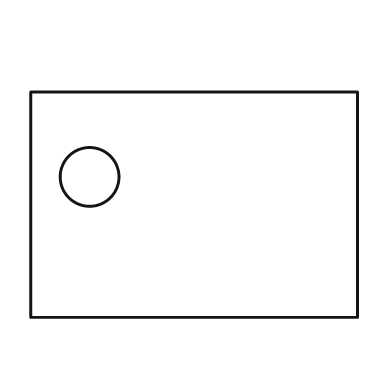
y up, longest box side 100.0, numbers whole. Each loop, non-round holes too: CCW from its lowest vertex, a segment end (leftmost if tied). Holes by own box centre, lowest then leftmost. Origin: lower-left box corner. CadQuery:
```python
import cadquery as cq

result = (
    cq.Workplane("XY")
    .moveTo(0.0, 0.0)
    .lineTo(100.0, 0.0)
    .lineTo(100.0, 69.0)
    .lineTo(0.0, 69.0)
    .close()
    .moveTo(18.0, 43.0)
    .circle(9.0)
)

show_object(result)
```